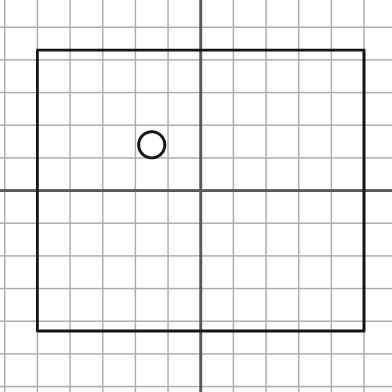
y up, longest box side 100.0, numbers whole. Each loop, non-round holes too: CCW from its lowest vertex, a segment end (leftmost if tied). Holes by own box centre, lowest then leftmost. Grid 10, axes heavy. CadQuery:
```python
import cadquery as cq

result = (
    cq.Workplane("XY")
    .moveTo(-50.0, -43.0)
    .lineTo(50.0, -43.0)
    .lineTo(50.0, 43.0)
    .lineTo(-50.0, 43.0)
    .close()
    .moveTo(-15.0, 14.0)
    .circle(4.0)
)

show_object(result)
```